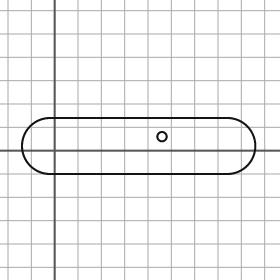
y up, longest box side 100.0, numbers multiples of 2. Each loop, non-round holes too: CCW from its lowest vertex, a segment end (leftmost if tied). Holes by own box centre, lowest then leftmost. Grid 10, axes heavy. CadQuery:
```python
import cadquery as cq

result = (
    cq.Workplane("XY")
    .moveTo(-2.0, -10.0)
    .lineTo(74.0, -10.0)
    .threePointArc((86.0, 2.0), (74.0, 14.0))
    .lineTo(-2.0, 14.0)
    .threePointArc((-14.0, 2.0), (-2.0, -10.0))
    .close()
    .moveTo(46.0, 6.0)
    .circle(2.0)
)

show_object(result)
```